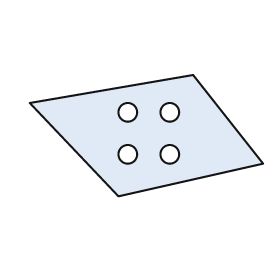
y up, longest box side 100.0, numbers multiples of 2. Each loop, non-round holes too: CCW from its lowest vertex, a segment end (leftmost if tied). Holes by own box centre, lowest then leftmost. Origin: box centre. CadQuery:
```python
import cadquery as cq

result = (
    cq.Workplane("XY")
    .moveTo(-12.0, -26.0)
    .lineTo(50.0, -12.0)
    .lineTo(20.0, 26.0)
    .lineTo(-50.0, 14.0)
    .close()
    .moveTo(-8.0, -8.0)
    .circle(4.0)
    .moveTo(10.0, -8.0)
    .circle(4.0)
    .moveTo(-8.0, 10.0)
    .circle(4.0)
    .moveTo(10.0, 10.0)
    .circle(4.0)
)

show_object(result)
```